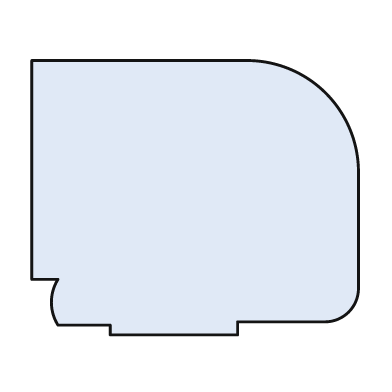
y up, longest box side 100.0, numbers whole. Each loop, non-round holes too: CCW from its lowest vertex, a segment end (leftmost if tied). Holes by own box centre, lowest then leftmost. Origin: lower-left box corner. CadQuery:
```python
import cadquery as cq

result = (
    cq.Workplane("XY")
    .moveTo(24.0, 0.0)
    .lineTo(63.0, 0.0)
    .lineTo(63.0, 4.0)
    .lineTo(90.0, 4.0)
    .threePointArc((97.0, 7.0), (100.0, 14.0))
    .lineTo(100.0, 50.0)
    .threePointArc((90.0, 74.0), (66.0, 84.0))
    .lineTo(0.0, 84.0)
    .lineTo(0.0, 17.0)
    .lineTo(8.0, 17.0)
    .threePointArc((6.0, 10.0), (8.0, 3.0))
    .lineTo(24.0, 3.0)
    .close()
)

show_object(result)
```